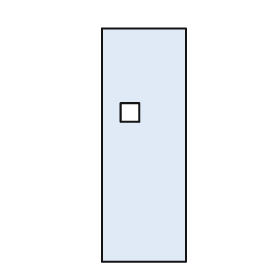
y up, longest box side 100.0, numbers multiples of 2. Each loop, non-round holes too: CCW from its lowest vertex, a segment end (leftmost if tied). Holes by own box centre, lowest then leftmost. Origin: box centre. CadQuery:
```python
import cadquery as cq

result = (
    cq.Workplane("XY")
    .moveTo(-18.0, -50.0)
    .lineTo(18.0, -50.0)
    .lineTo(18.0, 50.0)
    .lineTo(-18.0, 50.0)
    .close()
    .moveTo(-10.0, 10.0)
    .lineTo(-2.0, 10.0)
    .lineTo(-2.0, 18.0)
    .lineTo(-10.0, 18.0)
    .close()
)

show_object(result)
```